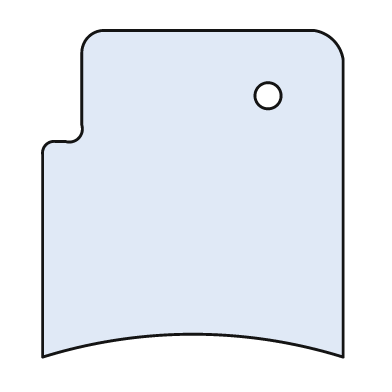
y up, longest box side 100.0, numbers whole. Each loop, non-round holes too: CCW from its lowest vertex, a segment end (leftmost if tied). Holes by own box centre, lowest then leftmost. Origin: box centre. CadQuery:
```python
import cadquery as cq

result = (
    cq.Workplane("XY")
    .moveTo(-46.0, -50.0)
    .threePointArc((0.0, -43.0), (46.0, -50.0))
    .lineTo(46.0, 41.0)
    .threePointArc((43.0, 47.0), (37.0, 50.0))
    .lineTo(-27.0, 50.0)
    .threePointArc((-32.0, 48.0), (-34.0, 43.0))
    .lineTo(-34.0, 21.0)
    .threePointArc((-35.0, 17.0), (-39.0, 16.0))
    .lineTo(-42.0, 16.0)
    .threePointArc((-45.0, 15.0), (-46.0, 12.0))
    .close()
    .moveTo(23.0, 30.0)
    .circle(4.0)
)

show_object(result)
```